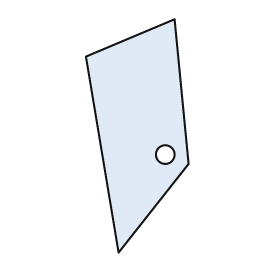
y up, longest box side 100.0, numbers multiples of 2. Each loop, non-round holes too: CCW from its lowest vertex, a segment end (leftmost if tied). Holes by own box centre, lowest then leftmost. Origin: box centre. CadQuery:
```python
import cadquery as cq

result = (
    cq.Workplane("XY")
    .moveTo(-8.0, -50.0)
    .lineTo(22.0, -12.0)
    .lineTo(16.0, 50.0)
    .lineTo(-22.0, 34.0)
    .close()
    .moveTo(12.0, -8.0)
    .circle(4.0)
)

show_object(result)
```